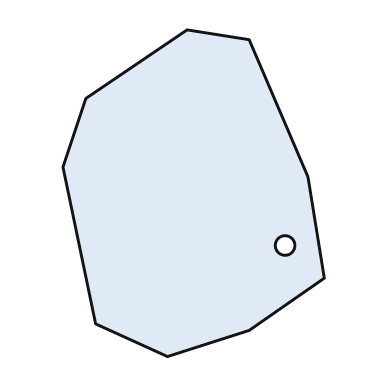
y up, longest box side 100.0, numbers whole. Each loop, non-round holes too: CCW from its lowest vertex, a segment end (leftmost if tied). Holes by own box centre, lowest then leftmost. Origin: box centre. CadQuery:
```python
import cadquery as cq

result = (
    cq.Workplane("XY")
    .moveTo(-8.0, -50.0)
    .lineTo(17.0, -42.0)
    .lineTo(40.0, -26.0)
    .lineTo(35.0, 5.0)
    .lineTo(17.0, 47.0)
    .lineTo(-2.0, 50.0)
    .lineTo(-33.0, 29.0)
    .lineTo(-40.0, 8.0)
    .lineTo(-30.0, -40.0)
    .close()
    .moveTo(28.0, -16.0)
    .circle(3.0)
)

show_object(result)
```